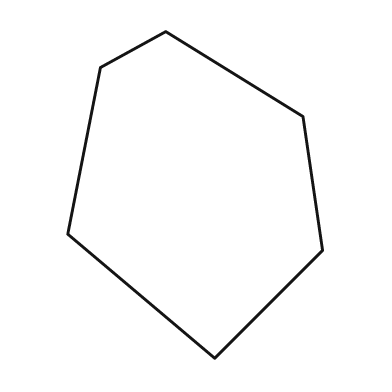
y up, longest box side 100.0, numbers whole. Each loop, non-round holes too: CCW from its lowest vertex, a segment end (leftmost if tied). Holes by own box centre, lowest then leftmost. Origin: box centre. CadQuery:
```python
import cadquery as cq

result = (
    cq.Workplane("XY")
    .moveTo(6.0, -50.0)
    .lineTo(39.0, -17.0)
    .lineTo(33.0, 24.0)
    .lineTo(-9.0, 50.0)
    .lineTo(-29.0, 39.0)
    .lineTo(-39.0, -12.0)
    .close()
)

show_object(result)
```